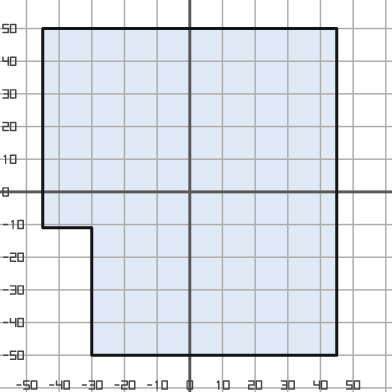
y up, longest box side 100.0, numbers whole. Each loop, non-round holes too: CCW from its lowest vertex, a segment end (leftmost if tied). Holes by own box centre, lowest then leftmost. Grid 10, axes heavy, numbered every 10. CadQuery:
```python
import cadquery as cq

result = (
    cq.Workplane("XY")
    .moveTo(-30.0, -50.0)
    .lineTo(45.0, -50.0)
    .lineTo(45.0, 50.0)
    .lineTo(-45.0, 50.0)
    .lineTo(-45.0, -11.0)
    .lineTo(-30.0, -11.0)
    .close()
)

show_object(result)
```